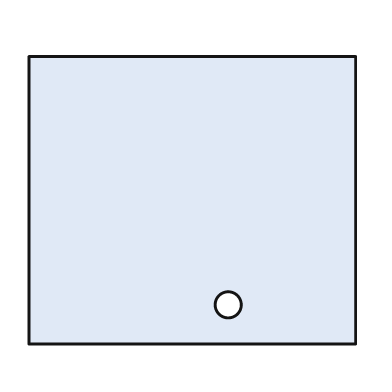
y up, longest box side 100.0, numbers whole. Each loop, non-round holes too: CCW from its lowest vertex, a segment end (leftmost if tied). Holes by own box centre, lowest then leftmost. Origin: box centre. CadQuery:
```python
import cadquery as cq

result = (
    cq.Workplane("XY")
    .moveTo(-50.0, -44.0)
    .lineTo(50.0, -44.0)
    .lineTo(50.0, 44.0)
    .lineTo(-50.0, 44.0)
    .close()
    .moveTo(11.0, -32.0)
    .circle(4.0)
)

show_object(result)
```